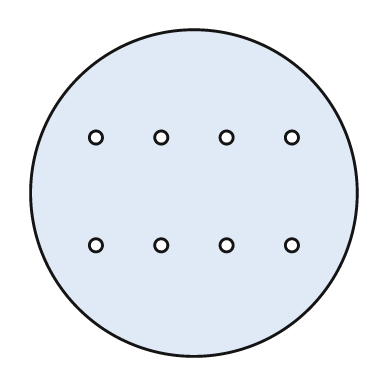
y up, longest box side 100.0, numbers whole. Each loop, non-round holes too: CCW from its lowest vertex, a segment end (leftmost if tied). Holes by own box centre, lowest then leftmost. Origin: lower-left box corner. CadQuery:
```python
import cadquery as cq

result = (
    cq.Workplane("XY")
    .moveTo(50.0, 50.0)
    .circle(50.0)
    .moveTo(20.0, 34.0)
    .circle(2.0)
    .moveTo(40.0, 34.0)
    .circle(2.0)
    .moveTo(60.0, 34.0)
    .circle(2.0)
    .moveTo(80.0, 34.0)
    .circle(2.0)
    .moveTo(20.0, 67.0)
    .circle(2.0)
    .moveTo(40.0, 67.0)
    .circle(2.0)
    .moveTo(60.0, 67.0)
    .circle(2.0)
    .moveTo(80.0, 67.0)
    .circle(2.0)
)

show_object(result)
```